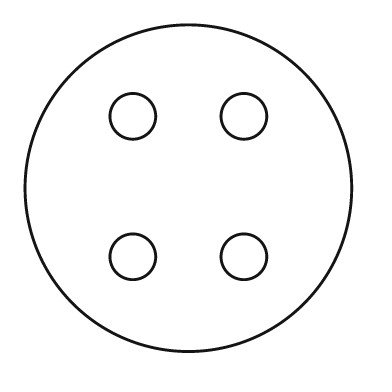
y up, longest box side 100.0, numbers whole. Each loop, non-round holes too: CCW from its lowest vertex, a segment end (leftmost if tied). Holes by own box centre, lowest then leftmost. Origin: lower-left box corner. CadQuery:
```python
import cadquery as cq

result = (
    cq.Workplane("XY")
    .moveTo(50.0, 50.0)
    .circle(50.0)
    .moveTo(33.0, 29.0)
    .circle(7.0)
    .moveTo(67.0, 29.0)
    .circle(7.0)
    .moveTo(33.0, 72.0)
    .circle(7.0)
    .moveTo(67.0, 72.0)
    .circle(7.0)
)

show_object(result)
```